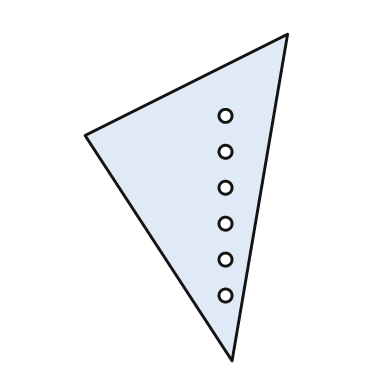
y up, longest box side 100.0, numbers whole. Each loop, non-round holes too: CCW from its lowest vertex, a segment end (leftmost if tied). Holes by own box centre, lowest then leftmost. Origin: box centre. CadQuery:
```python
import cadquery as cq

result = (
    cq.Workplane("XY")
    .moveTo(14.0, -50.0)
    .lineTo(31.0, 50.0)
    .lineTo(-31.0, 19.0)
    .close()
    .moveTo(12.0, -30.0)
    .circle(2.0)
    .moveTo(12.0, -19.0)
    .circle(2.0)
    .moveTo(12.0, -8.0)
    .circle(2.0)
    .moveTo(12.0, 3.0)
    .circle(2.0)
    .moveTo(12.0, 14.0)
    .circle(2.0)
    .moveTo(12.0, 25.0)
    .circle(2.0)
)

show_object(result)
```